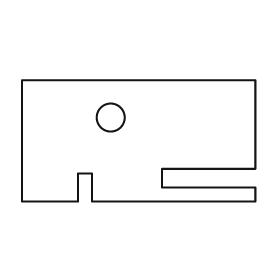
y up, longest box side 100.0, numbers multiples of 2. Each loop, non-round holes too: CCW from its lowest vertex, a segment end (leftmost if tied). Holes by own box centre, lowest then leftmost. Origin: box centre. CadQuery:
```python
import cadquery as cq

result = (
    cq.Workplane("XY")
    .moveTo(-50.0, -26.0)
    .lineTo(-26.0, -26.0)
    .lineTo(-26.0, -14.0)
    .lineTo(-20.0, -14.0)
    .lineTo(-20.0, -26.0)
    .lineTo(50.0, -26.0)
    .lineTo(50.0, -20.0)
    .lineTo(10.0, -20.0)
    .lineTo(10.0, -12.0)
    .lineTo(50.0, -12.0)
    .lineTo(50.0, 26.0)
    .lineTo(-50.0, 26.0)
    .close()
    .moveTo(-12.0, 10.0)
    .circle(6.0)
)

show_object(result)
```